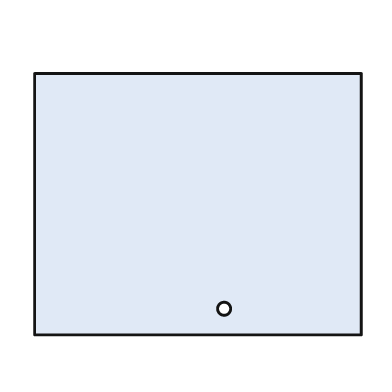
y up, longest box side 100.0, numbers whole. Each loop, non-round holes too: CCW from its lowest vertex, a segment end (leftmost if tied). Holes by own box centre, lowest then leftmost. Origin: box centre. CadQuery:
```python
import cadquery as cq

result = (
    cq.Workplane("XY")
    .moveTo(-50.0, -40.0)
    .lineTo(50.0, -40.0)
    .lineTo(50.0, 40.0)
    .lineTo(-50.0, 40.0)
    .close()
    .moveTo(8.0, -32.0)
    .circle(2.0)
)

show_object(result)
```